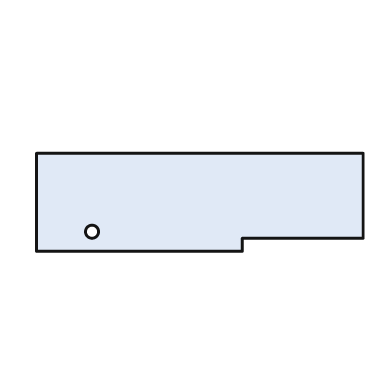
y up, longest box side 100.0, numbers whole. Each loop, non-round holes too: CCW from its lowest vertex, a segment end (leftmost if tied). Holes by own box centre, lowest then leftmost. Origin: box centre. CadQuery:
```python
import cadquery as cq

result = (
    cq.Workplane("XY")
    .moveTo(-50.0, -15.0)
    .lineTo(13.0, -15.0)
    .lineTo(13.0, -11.0)
    .lineTo(50.0, -11.0)
    .lineTo(50.0, 15.0)
    .lineTo(-50.0, 15.0)
    .close()
    .moveTo(-33.0, -9.0)
    .circle(2.0)
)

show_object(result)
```